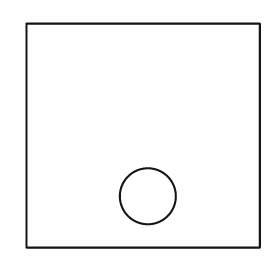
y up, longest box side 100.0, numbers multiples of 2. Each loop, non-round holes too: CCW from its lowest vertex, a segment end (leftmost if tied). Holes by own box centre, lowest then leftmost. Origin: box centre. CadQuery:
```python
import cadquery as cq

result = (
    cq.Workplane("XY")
    .moveTo(-50.0, -48.0)
    .lineTo(50.0, -48.0)
    .lineTo(50.0, 48.0)
    .lineTo(-50.0, 48.0)
    .close()
    .moveTo(2.0, -26.0)
    .circle(12.0)
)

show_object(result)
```